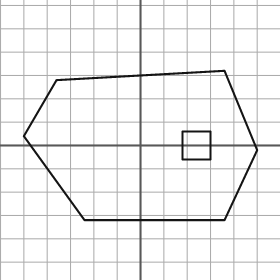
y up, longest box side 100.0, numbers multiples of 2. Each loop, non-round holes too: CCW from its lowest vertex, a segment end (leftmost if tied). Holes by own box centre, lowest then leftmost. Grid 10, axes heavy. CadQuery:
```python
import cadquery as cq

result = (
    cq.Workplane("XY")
    .moveTo(-24.0, -32.0)
    .lineTo(36.0, -32.0)
    .lineTo(50.0, -2.0)
    .lineTo(36.0, 32.0)
    .lineTo(-36.0, 28.0)
    .lineTo(-50.0, 4.0)
    .close()
    .moveTo(18.0, -6.0)
    .lineTo(30.0, -6.0)
    .lineTo(30.0, 6.0)
    .lineTo(18.0, 6.0)
    .close()
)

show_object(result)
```